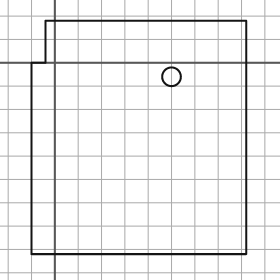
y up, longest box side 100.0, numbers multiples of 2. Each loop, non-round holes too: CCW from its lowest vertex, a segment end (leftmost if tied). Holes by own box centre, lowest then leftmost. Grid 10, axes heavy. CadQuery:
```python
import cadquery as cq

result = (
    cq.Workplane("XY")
    .moveTo(-10.0, -82.0)
    .lineTo(82.0, -82.0)
    .lineTo(82.0, 18.0)
    .lineTo(-4.0, 18.0)
    .lineTo(-4.0, 0.0)
    .lineTo(-10.0, 0.0)
    .close()
    .moveTo(50.0, -6.0)
    .circle(4.0)
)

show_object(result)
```